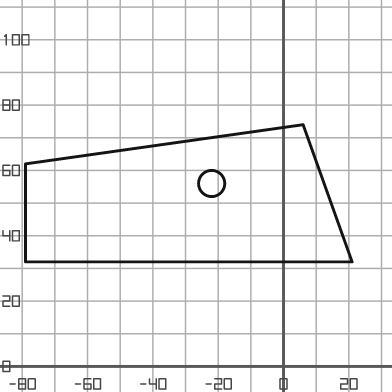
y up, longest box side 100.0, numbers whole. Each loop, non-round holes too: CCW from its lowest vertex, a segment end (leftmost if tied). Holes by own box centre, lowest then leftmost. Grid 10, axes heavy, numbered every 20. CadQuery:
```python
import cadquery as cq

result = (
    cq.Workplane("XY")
    .moveTo(-79.0, 32.0)
    .lineTo(21.0, 32.0)
    .lineTo(6.0, 74.0)
    .lineTo(-79.0, 62.0)
    .close()
    .moveTo(-22.0, 56.0)
    .circle(4.0)
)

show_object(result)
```